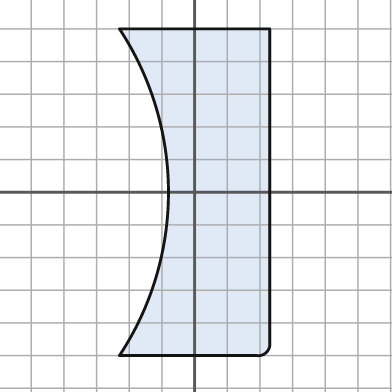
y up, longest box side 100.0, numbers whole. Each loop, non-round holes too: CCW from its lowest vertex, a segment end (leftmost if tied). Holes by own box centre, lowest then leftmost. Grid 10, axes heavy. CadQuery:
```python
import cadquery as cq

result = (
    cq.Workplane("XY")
    .moveTo(-23.0, -50.0)
    .lineTo(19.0, -50.0)
    .threePointArc((22.0, -49.0), (23.0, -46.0))
    .lineTo(23.0, 50.0)
    .lineTo(-23.0, 50.0)
    .threePointArc((-8.0, 0.0), (-23.0, -50.0))
    .close()
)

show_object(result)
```